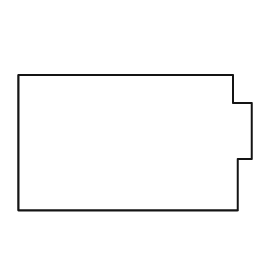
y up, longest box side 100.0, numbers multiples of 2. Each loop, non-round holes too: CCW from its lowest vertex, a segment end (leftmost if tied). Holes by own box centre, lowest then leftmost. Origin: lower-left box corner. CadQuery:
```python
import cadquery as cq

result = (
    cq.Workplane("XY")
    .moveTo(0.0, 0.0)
    .lineTo(94.0, 0.0)
    .lineTo(94.0, 22.0)
    .lineTo(100.0, 22.0)
    .lineTo(100.0, 46.0)
    .lineTo(92.0, 46.0)
    .lineTo(92.0, 58.0)
    .lineTo(0.0, 58.0)
    .close()
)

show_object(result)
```